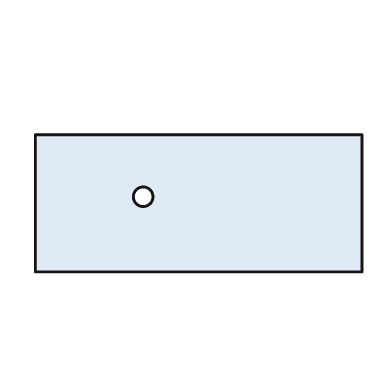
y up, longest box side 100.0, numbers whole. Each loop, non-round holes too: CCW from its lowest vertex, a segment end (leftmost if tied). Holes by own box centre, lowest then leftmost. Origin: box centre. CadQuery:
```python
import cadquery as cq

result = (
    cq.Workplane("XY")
    .moveTo(-50.0, -21.0)
    .lineTo(50.0, -21.0)
    .lineTo(50.0, 21.0)
    .lineTo(-50.0, 21.0)
    .close()
    .moveTo(-17.0, 2.0)
    .circle(3.0)
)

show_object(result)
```